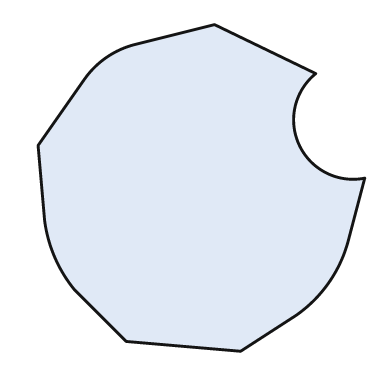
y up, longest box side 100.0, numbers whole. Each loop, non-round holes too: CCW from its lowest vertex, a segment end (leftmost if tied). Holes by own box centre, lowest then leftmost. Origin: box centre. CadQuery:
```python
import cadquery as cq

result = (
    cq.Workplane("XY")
    .moveTo(12.0, -50.0)
    .lineTo(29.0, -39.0)
    .threePointArc((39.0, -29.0), (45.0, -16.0))
    .lineTo(50.0, 3.0)
    .threePointArc((30.0, 13.0), (35.0, 35.0))
    .lineTo(4.0, 50.0)
    .lineTo(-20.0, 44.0)
    .threePointArc((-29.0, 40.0), (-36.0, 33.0))
    .lineTo(-50.0, 13.0)
    .lineTo(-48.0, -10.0)
    .threePointArc((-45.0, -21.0), (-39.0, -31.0))
    .lineTo(-23.0, -47.0)
    .close()
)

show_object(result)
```